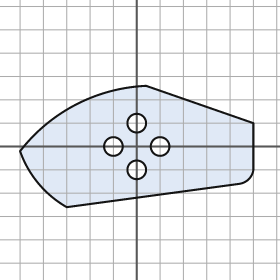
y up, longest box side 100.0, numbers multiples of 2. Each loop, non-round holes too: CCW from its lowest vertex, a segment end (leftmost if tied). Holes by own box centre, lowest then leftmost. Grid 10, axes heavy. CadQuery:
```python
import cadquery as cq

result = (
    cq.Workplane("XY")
    .moveTo(-30.0, -26.0)
    .lineTo(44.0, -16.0)
    .threePointArc((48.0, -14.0), (50.0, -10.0))
    .lineTo(50.0, 10.0)
    .lineTo(4.0, 26.0)
    .threePointArc((-26.0, 18.0), (-50.0, -2.0))
    .threePointArc((-42.0, -16.0), (-30.0, -26.0))
    .close()
    .moveTo(0.0, -10.0)
    .circle(4.0)
    .moveTo(-10.0, 0.0)
    .circle(4.0)
    .moveTo(10.0, 0.0)
    .circle(4.0)
    .moveTo(0.0, 10.0)
    .circle(4.0)
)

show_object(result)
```